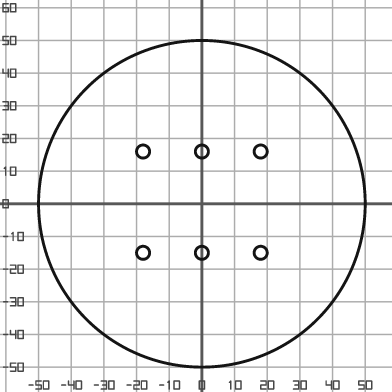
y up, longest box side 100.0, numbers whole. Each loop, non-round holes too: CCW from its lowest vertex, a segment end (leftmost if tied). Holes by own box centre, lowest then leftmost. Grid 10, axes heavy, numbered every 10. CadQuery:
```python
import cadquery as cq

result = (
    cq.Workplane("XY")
    .moveTo(0.0, 0.0)
    .circle(50.0)
    .moveTo(-18.0, -15.0)
    .circle(2.0)
    .moveTo(0.0, -15.0)
    .circle(2.0)
    .moveTo(18.0, -15.0)
    .circle(2.0)
    .moveTo(-18.0, 16.0)
    .circle(2.0)
    .moveTo(0.0, 16.0)
    .circle(2.0)
    .moveTo(18.0, 16.0)
    .circle(2.0)
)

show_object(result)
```